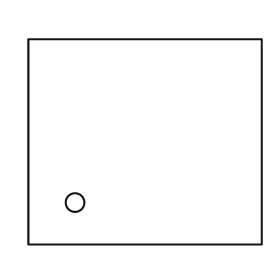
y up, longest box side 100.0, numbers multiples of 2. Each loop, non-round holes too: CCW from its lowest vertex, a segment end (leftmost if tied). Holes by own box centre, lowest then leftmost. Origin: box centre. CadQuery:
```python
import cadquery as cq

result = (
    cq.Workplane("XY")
    .moveTo(-50.0, -44.0)
    .lineTo(50.0, -44.0)
    .lineTo(50.0, 44.0)
    .lineTo(-50.0, 44.0)
    .close()
    .moveTo(-30.0, -26.0)
    .circle(4.0)
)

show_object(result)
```